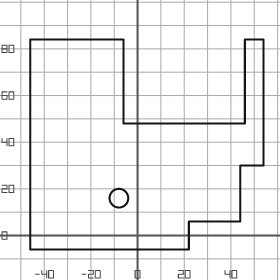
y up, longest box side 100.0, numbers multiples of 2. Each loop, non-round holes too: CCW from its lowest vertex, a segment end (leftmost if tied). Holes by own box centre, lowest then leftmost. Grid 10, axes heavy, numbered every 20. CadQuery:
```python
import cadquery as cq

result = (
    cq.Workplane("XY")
    .moveTo(-46.0, -6.0)
    .lineTo(22.0, -6.0)
    .lineTo(22.0, 6.0)
    .lineTo(44.0, 6.0)
    .lineTo(44.0, 30.0)
    .lineTo(54.0, 30.0)
    .lineTo(54.0, 84.0)
    .lineTo(46.0, 84.0)
    .lineTo(46.0, 48.0)
    .lineTo(-6.0, 48.0)
    .lineTo(-6.0, 84.0)
    .lineTo(-46.0, 84.0)
    .close()
    .moveTo(-8.0, 16.0)
    .circle(4.0)
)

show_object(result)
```